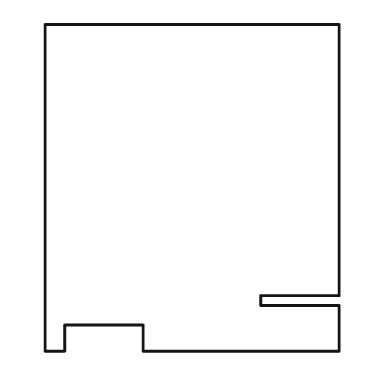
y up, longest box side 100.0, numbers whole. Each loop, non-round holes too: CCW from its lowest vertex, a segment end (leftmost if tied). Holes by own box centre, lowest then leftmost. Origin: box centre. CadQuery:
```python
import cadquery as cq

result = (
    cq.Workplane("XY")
    .moveTo(-45.0, -50.0)
    .lineTo(-39.0, -50.0)
    .lineTo(-39.0, -42.0)
    .lineTo(-15.0, -42.0)
    .lineTo(-15.0, -50.0)
    .lineTo(45.0, -50.0)
    .lineTo(45.0, -36.0)
    .lineTo(21.0, -36.0)
    .lineTo(21.0, -33.0)
    .lineTo(45.0, -33.0)
    .lineTo(45.0, 50.0)
    .lineTo(-45.0, 50.0)
    .close()
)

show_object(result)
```